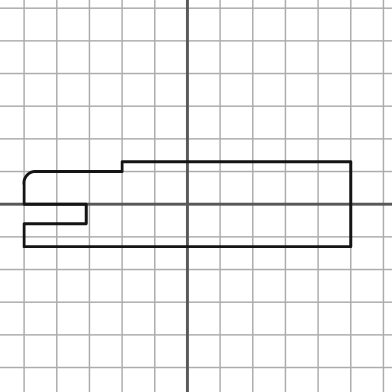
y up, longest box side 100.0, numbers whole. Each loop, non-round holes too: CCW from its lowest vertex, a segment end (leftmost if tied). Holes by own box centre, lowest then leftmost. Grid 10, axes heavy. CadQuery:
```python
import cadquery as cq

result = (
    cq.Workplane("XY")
    .moveTo(-50.0, -13.0)
    .lineTo(50.0, -13.0)
    .lineTo(50.0, 13.0)
    .lineTo(-20.0, 13.0)
    .lineTo(-20.0, 10.0)
    .lineTo(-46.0, 10.0)
    .threePointArc((-49.0, 9.0), (-50.0, 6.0))
    .lineTo(-50.0, 0.0)
    .lineTo(-31.0, 0.0)
    .lineTo(-31.0, -6.0)
    .lineTo(-50.0, -6.0)
    .close()
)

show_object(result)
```